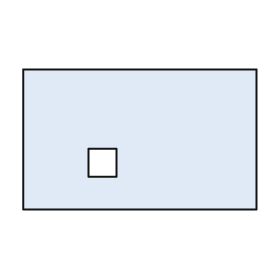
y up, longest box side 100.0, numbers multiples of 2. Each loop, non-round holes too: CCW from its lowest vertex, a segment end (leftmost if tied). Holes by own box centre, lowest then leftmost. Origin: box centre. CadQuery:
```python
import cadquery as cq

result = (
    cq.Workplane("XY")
    .moveTo(-50.0, -30.0)
    .lineTo(50.0, -30.0)
    .lineTo(50.0, 30.0)
    .lineTo(-50.0, 30.0)
    .close()
    .moveTo(-22.0, -16.0)
    .lineTo(-10.0, -16.0)
    .lineTo(-10.0, -4.0)
    .lineTo(-22.0, -4.0)
    .close()
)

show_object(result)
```